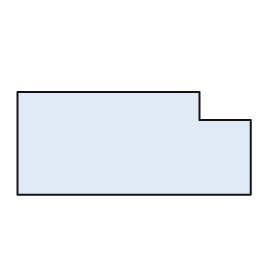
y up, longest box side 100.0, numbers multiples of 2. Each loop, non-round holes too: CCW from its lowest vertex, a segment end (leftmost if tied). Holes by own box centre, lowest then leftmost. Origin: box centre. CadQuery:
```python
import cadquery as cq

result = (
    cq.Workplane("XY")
    .moveTo(-50.0, -22.0)
    .lineTo(50.0, -22.0)
    .lineTo(50.0, 10.0)
    .lineTo(28.0, 10.0)
    .lineTo(28.0, 22.0)
    .lineTo(-50.0, 22.0)
    .close()
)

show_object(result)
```